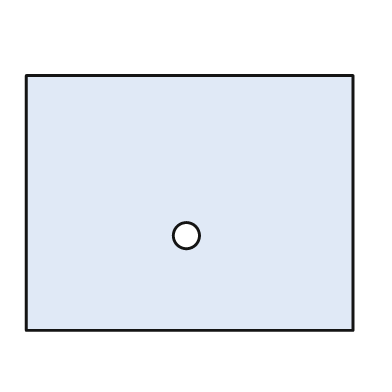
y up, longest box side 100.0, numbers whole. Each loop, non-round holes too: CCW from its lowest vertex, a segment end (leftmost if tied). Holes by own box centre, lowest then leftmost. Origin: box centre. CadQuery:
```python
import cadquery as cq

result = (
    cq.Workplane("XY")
    .moveTo(-50.0, -39.0)
    .lineTo(50.0, -39.0)
    .lineTo(50.0, 39.0)
    .lineTo(-50.0, 39.0)
    .close()
    .moveTo(-1.0, -10.0)
    .circle(4.0)
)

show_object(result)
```